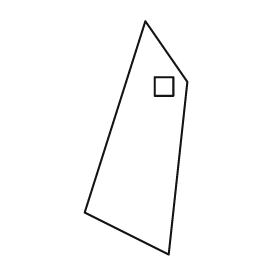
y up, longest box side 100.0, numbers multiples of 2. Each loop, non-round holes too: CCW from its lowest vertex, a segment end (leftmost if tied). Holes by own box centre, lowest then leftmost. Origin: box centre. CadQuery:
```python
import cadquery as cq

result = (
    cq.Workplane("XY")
    .moveTo(14.0, -50.0)
    .lineTo(22.0, 24.0)
    .lineTo(4.0, 50.0)
    .lineTo(-22.0, -32.0)
    .close()
    .moveTo(8.0, 18.0)
    .lineTo(16.0, 18.0)
    .lineTo(16.0, 26.0)
    .lineTo(8.0, 26.0)
    .close()
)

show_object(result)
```